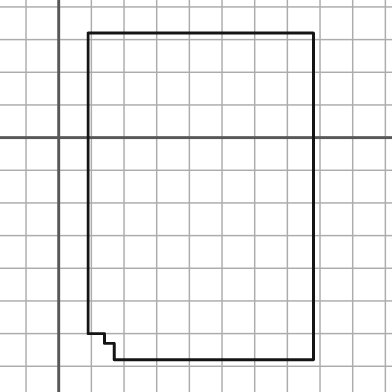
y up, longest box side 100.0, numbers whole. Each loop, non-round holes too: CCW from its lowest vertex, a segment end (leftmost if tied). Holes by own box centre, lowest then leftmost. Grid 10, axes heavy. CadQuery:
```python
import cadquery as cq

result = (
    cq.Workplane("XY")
    .moveTo(17.0, -68.0)
    .lineTo(78.0, -68.0)
    .lineTo(78.0, 32.0)
    .lineTo(9.0, 32.0)
    .lineTo(9.0, -60.0)
    .lineTo(14.0, -60.0)
    .lineTo(14.0, -63.0)
    .lineTo(17.0, -63.0)
    .close()
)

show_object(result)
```